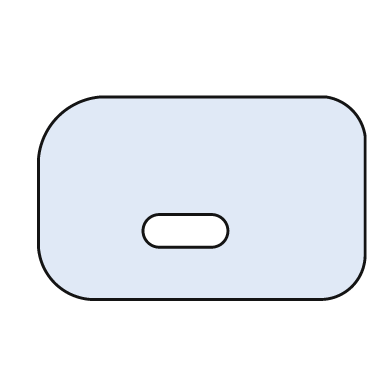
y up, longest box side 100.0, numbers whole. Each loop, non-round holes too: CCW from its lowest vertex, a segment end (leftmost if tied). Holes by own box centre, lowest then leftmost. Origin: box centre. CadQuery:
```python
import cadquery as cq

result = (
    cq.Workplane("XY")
    .moveTo(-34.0, -31.0)
    .lineTo(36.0, -31.0)
    .threePointArc((46.0, -27.0), (50.0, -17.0))
    .lineTo(50.0, 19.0)
    .threePointArc((46.0, 27.0), (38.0, 31.0))
    .lineTo(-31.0, 31.0)
    .threePointArc((-44.0, 25.0), (-50.0, 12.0))
    .lineTo(-50.0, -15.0)
    .threePointArc((-45.0, -26.0), (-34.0, -31.0))
    .close()
    .moveTo(-13.0, -15.0)
    .lineTo(3.0, -15.0)
    .threePointArc((8.0, -10.0), (3.0, -5.0))
    .lineTo(-13.0, -5.0)
    .threePointArc((-18.0, -10.0), (-13.0, -15.0))
    .close()
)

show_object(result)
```